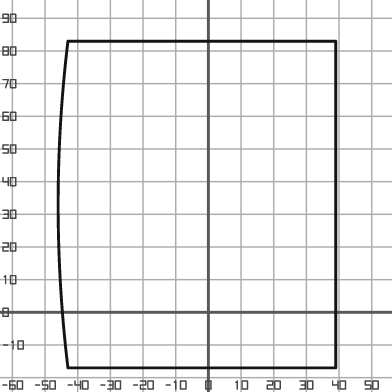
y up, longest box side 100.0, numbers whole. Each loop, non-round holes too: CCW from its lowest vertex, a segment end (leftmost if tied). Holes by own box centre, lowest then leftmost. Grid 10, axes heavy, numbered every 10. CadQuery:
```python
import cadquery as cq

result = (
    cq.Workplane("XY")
    .moveTo(-43.0, -17.0)
    .lineTo(39.0, -17.0)
    .lineTo(39.0, 83.0)
    .lineTo(-43.0, 83.0)
    .threePointArc((-46.0, 33.0), (-43.0, -17.0))
    .close()
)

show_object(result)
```